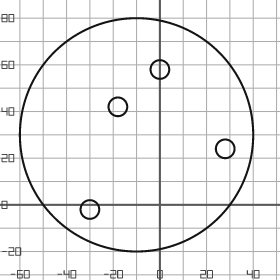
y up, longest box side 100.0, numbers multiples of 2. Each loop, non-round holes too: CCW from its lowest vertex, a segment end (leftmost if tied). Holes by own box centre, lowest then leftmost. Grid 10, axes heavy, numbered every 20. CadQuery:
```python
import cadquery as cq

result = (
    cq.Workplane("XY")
    .moveTo(-10.0, 30.0)
    .circle(50.0)
    .moveTo(-30.0, -2.0)
    .circle(4.0)
    .moveTo(28.0, 24.0)
    .circle(4.0)
    .moveTo(-18.0, 42.0)
    .circle(4.0)
    .moveTo(0.0, 58.0)
    .circle(4.0)
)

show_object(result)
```